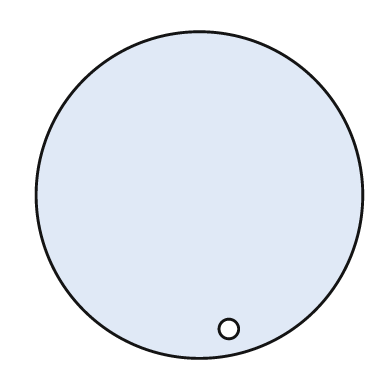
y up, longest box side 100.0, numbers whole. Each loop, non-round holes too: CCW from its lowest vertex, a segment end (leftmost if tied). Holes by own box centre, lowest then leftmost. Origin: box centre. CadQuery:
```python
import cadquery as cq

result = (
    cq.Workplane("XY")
    .moveTo(0.0, 0.0)
    .circle(50.0)
    .moveTo(9.0, -41.0)
    .circle(3.0)
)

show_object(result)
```